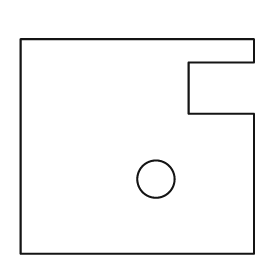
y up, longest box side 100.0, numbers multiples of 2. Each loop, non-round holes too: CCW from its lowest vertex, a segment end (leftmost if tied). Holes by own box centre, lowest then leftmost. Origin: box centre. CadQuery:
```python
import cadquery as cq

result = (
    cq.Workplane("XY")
    .moveTo(-50.0, -46.0)
    .lineTo(50.0, -46.0)
    .lineTo(50.0, 14.0)
    .lineTo(22.0, 14.0)
    .lineTo(22.0, 36.0)
    .lineTo(50.0, 36.0)
    .lineTo(50.0, 46.0)
    .lineTo(-50.0, 46.0)
    .close()
    .moveTo(8.0, -14.0)
    .circle(8.0)
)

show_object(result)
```